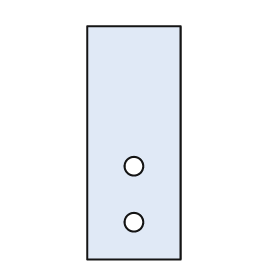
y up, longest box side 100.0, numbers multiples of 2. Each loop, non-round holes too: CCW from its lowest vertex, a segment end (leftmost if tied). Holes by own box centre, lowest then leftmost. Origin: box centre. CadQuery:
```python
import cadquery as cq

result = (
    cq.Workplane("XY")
    .moveTo(-20.0, -50.0)
    .lineTo(20.0, -50.0)
    .lineTo(20.0, 50.0)
    .lineTo(-20.0, 50.0)
    .close()
    .moveTo(0.0, -34.0)
    .circle(4.0)
    .moveTo(0.0, -10.0)
    .circle(4.0)
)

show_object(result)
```